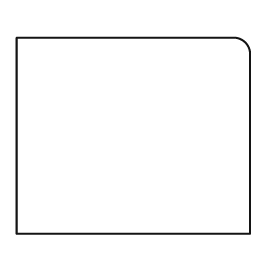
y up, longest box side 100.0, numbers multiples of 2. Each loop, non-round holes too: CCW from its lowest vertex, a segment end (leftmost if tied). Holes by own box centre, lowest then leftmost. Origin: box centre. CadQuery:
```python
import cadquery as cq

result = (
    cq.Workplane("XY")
    .moveTo(-50.0, -42.0)
    .lineTo(50.0, -42.0)
    .lineTo(50.0, 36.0)
    .threePointArc((48.0, 40.0), (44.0, 42.0))
    .lineTo(-50.0, 42.0)
    .close()
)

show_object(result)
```